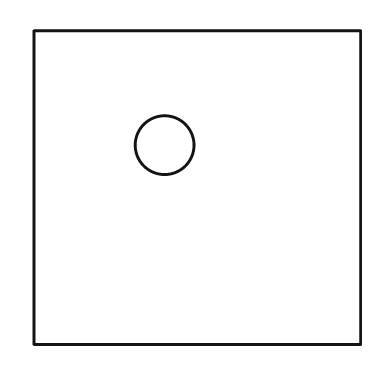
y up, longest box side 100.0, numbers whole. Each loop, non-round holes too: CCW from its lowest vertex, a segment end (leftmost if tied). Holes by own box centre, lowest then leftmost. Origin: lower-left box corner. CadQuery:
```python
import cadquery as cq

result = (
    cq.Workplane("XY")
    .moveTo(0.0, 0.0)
    .lineTo(100.0, 0.0)
    .lineTo(100.0, 96.0)
    .lineTo(0.0, 96.0)
    .close()
    .moveTo(40.0, 61.0)
    .circle(9.0)
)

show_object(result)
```